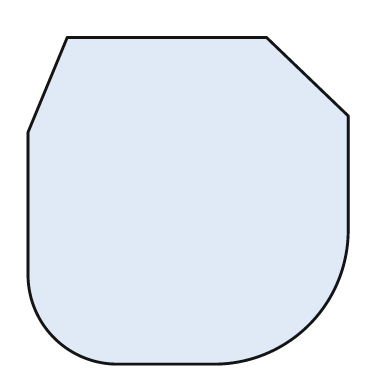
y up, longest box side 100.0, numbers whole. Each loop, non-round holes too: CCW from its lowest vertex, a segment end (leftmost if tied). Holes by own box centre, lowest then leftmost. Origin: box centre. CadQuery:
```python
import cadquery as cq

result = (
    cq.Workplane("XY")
    .moveTo(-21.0, -50.0)
    .lineTo(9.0, -50.0)
    .threePointArc((37.0, -38.0), (49.0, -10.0))
    .lineTo(49.0, 26.0)
    .lineTo(24.0, 50.0)
    .lineTo(-37.0, 50.0)
    .lineTo(-49.0, 21.0)
    .lineTo(-49.0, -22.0)
    .threePointArc((-41.0, -42.0), (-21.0, -50.0))
    .close()
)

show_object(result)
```